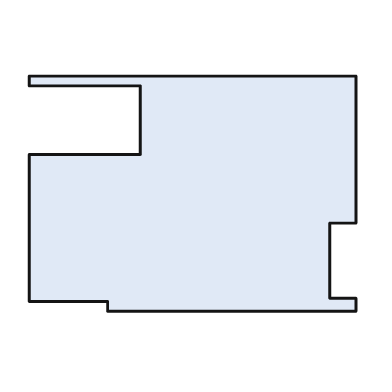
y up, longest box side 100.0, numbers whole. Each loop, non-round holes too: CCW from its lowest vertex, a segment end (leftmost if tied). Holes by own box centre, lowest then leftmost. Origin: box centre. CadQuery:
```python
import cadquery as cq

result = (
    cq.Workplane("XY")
    .moveTo(-26.0, -36.0)
    .lineTo(50.0, -36.0)
    .lineTo(50.0, -32.0)
    .lineTo(42.0, -32.0)
    .lineTo(42.0, -9.0)
    .lineTo(50.0, -9.0)
    .lineTo(50.0, 36.0)
    .lineTo(-50.0, 36.0)
    .lineTo(-50.0, 33.0)
    .lineTo(-16.0, 33.0)
    .lineTo(-16.0, 12.0)
    .lineTo(-50.0, 12.0)
    .lineTo(-50.0, -33.0)
    .lineTo(-26.0, -33.0)
    .close()
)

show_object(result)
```